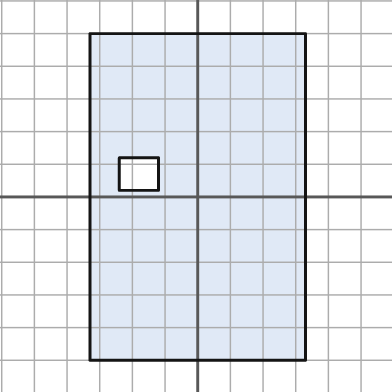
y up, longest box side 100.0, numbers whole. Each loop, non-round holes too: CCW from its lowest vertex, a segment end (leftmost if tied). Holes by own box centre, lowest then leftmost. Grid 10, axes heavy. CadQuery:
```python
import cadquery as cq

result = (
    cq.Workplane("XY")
    .moveTo(-33.0, -50.0)
    .lineTo(33.0, -50.0)
    .lineTo(33.0, 50.0)
    .lineTo(-33.0, 50.0)
    .close()
    .moveTo(-24.0, 2.0)
    .lineTo(-12.0, 2.0)
    .lineTo(-12.0, 12.0)
    .lineTo(-24.0, 12.0)
    .close()
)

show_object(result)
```